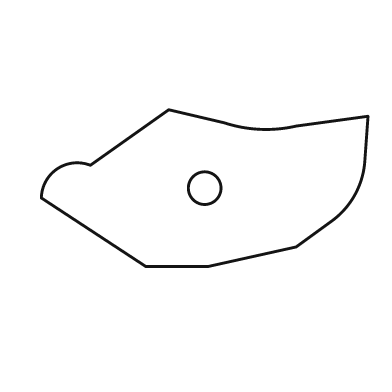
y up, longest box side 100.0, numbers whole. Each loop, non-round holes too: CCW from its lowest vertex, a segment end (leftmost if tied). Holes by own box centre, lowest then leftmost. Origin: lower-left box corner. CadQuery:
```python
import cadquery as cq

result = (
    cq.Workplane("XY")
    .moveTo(32.0, 0.0)
    .lineTo(51.0, 0.0)
    .lineTo(78.0, 6.0)
    .lineTo(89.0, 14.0)
    .threePointArc((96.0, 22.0), (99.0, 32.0))
    .lineTo(100.0, 46.0)
    .lineTo(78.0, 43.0)
    .threePointArc((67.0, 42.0), (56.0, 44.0))
    .lineTo(39.0, 48.0)
    .lineTo(15.0, 31.0)
    .threePointArc((5.0, 30.0), (0.0, 21.0))
    .close()
    .moveTo(50.0, 24.0)
    .circle(5.0)
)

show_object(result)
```